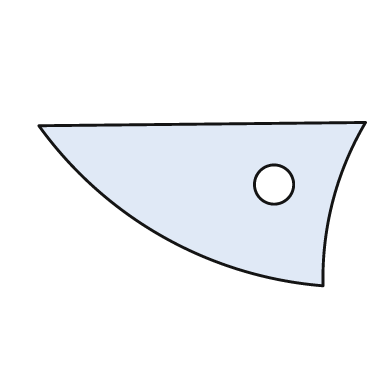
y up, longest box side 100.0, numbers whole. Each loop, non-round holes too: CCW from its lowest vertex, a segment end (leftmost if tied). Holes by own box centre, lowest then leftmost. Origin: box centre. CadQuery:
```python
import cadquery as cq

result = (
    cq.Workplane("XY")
    .moveTo(37.0, -25.0)
    .threePointArc((40.0, 1.0), (50.0, 25.0))
    .lineTo(-50.0, 24.0)
    .threePointArc((-12.0, -10.0), (37.0, -25.0))
    .close()
    .moveTo(22.0, 6.0)
    .circle(6.0)
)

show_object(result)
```